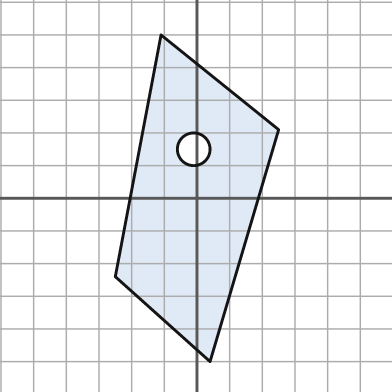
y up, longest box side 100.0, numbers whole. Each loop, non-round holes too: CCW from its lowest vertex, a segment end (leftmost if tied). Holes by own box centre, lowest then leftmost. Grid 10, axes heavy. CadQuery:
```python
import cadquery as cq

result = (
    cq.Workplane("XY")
    .moveTo(4.0, -50.0)
    .lineTo(25.0, 21.0)
    .lineTo(-11.0, 50.0)
    .lineTo(-25.0, -24.0)
    .close()
    .moveTo(-1.0, 15.0)
    .circle(5.0)
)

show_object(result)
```